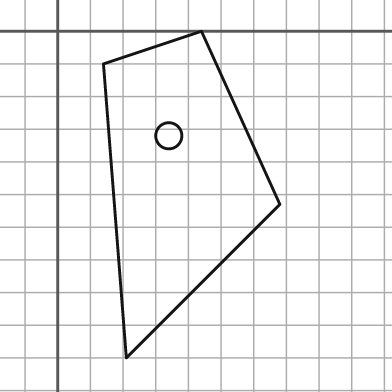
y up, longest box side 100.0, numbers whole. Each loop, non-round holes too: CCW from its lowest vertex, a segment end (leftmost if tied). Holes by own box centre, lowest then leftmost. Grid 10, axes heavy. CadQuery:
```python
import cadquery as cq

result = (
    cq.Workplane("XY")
    .moveTo(21.0, -100.0)
    .lineTo(68.0, -53.0)
    .lineTo(44.0, 0.0)
    .lineTo(14.0, -10.0)
    .close()
    .moveTo(34.0, -32.0)
    .circle(4.0)
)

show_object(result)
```